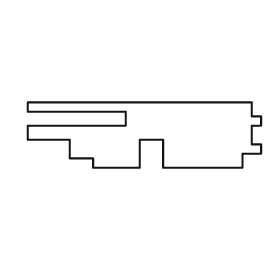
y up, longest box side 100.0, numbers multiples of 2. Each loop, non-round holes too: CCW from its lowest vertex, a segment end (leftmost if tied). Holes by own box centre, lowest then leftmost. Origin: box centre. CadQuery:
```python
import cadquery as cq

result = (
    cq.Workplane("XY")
    .moveTo(-22.0, -14.0)
    .lineTo(-2.0, -14.0)
    .lineTo(-2.0, -2.0)
    .lineTo(8.0, -2.0)
    .lineTo(8.0, -14.0)
    .lineTo(42.0, -14.0)
    .lineTo(42.0, -8.0)
    .lineTo(50.0, -8.0)
    .lineTo(50.0, -4.0)
    .lineTo(46.0, -4.0)
    .lineTo(46.0, 4.0)
    .lineTo(50.0, 4.0)
    .lineTo(50.0, 8.0)
    .lineTo(46.0, 8.0)
    .lineTo(46.0, 14.0)
    .lineTo(-50.0, 14.0)
    .lineTo(-50.0, 10.0)
    .lineTo(-8.0, 10.0)
    .lineTo(-8.0, 4.0)
    .lineTo(-50.0, 4.0)
    .lineTo(-50.0, -2.0)
    .lineTo(-32.0, -2.0)
    .lineTo(-32.0, -10.0)
    .lineTo(-22.0, -10.0)
    .close()
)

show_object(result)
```